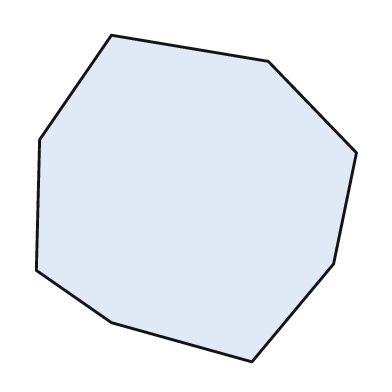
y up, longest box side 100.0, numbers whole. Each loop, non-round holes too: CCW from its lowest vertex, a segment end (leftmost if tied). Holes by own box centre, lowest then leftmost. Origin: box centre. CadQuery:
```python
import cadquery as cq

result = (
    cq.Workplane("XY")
    .moveTo(17.0, -50.0)
    .lineTo(42.0, -20.0)
    .lineTo(49.0, 14.0)
    .lineTo(22.0, 42.0)
    .lineTo(-26.0, 50.0)
    .lineTo(-48.0, 18.0)
    .lineTo(-49.0, -22.0)
    .lineTo(-26.0, -38.0)
    .close()
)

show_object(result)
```